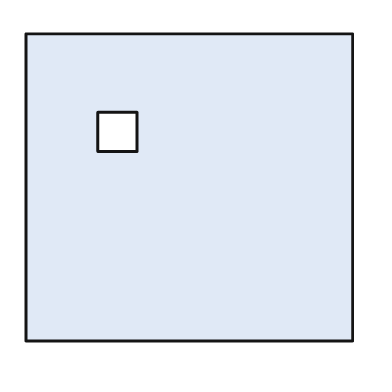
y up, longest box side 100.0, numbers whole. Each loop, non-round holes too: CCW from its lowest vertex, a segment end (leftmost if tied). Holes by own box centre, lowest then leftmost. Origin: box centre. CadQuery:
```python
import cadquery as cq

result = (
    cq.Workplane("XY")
    .moveTo(-50.0, -47.0)
    .lineTo(50.0, -47.0)
    .lineTo(50.0, 47.0)
    .lineTo(-50.0, 47.0)
    .close()
    .moveTo(-28.0, 11.0)
    .lineTo(-16.0, 11.0)
    .lineTo(-16.0, 23.0)
    .lineTo(-28.0, 23.0)
    .close()
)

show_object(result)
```